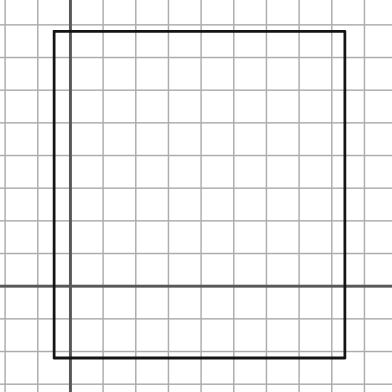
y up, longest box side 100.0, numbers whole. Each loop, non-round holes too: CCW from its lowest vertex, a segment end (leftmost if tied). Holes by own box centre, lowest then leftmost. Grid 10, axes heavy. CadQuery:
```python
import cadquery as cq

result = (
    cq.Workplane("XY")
    .moveTo(-5.0, -22.0)
    .lineTo(84.0, -22.0)
    .lineTo(84.0, 78.0)
    .lineTo(-5.0, 78.0)
    .close()
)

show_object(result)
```